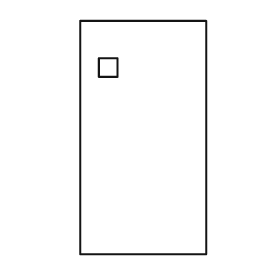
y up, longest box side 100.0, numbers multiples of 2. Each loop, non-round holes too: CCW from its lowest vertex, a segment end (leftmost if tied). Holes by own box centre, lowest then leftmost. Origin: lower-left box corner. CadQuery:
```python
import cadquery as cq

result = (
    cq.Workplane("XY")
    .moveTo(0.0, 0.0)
    .lineTo(54.0, 0.0)
    .lineTo(54.0, 100.0)
    .lineTo(0.0, 100.0)
    .close()
    .moveTo(8.0, 76.0)
    .lineTo(16.0, 76.0)
    .lineTo(16.0, 84.0)
    .lineTo(8.0, 84.0)
    .close()
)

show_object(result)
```